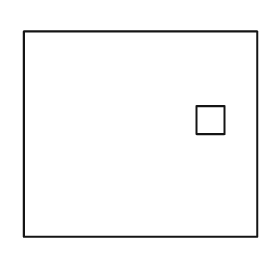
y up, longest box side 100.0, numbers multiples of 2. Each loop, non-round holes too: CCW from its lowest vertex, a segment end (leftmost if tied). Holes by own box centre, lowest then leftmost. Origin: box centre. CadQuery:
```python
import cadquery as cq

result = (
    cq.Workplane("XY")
    .moveTo(-50.0, -44.0)
    .lineTo(50.0, -44.0)
    .lineTo(50.0, 44.0)
    .lineTo(-50.0, 44.0)
    .close()
    .moveTo(24.0, 0.0)
    .lineTo(36.0, 0.0)
    .lineTo(36.0, 12.0)
    .lineTo(24.0, 12.0)
    .close()
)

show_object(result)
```